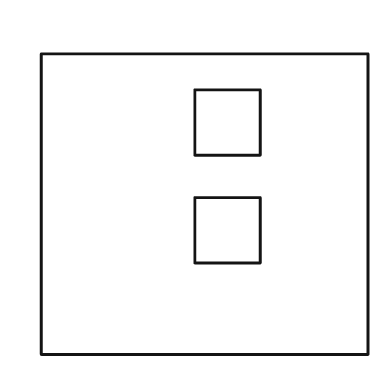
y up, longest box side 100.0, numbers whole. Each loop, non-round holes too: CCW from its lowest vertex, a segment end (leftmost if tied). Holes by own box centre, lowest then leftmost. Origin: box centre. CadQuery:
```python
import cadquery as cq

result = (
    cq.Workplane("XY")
    .moveTo(-50.0, -46.0)
    .lineTo(50.0, -46.0)
    .lineTo(50.0, 46.0)
    .lineTo(-50.0, 46.0)
    .close()
    .moveTo(-3.0, -18.0)
    .lineTo(17.0, -18.0)
    .lineTo(17.0, 2.0)
    .lineTo(-3.0, 2.0)
    .close()
    .moveTo(-3.0, 15.0)
    .lineTo(17.0, 15.0)
    .lineTo(17.0, 35.0)
    .lineTo(-3.0, 35.0)
    .close()
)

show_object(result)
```